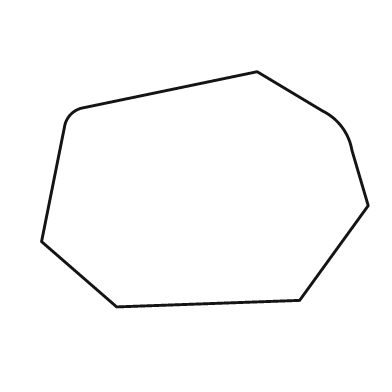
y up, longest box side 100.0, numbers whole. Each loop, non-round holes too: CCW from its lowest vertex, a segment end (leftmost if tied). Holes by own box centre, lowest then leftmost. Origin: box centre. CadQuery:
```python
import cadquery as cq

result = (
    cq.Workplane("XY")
    .moveTo(-27.0, -36.0)
    .lineTo(29.0, -34.0)
    .lineTo(50.0, -5.0)
    .lineTo(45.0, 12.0)
    .threePointArc((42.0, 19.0), (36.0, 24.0))
    .lineTo(16.0, 36.0)
    .lineTo(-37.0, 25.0)
    .threePointArc((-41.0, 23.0), (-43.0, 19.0))
    .lineTo(-50.0, -16.0)
    .close()
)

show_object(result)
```